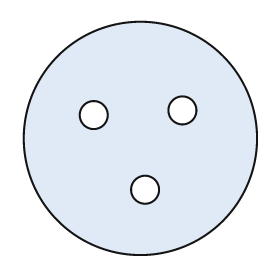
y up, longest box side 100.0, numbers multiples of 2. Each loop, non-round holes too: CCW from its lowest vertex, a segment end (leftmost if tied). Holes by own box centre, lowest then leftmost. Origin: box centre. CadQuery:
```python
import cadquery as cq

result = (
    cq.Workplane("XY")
    .moveTo(0.0, 0.0)
    .circle(50.0)
    .moveTo(2.0, -22.0)
    .circle(6.0)
    .moveTo(-20.0, 10.0)
    .circle(6.0)
    .moveTo(18.0, 12.0)
    .circle(6.0)
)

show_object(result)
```